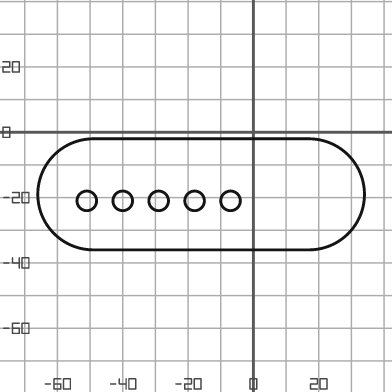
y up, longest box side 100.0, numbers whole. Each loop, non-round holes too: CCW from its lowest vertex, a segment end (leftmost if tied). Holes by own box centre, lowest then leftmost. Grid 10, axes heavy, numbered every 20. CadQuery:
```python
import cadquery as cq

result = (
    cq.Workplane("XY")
    .moveTo(-49.0, -36.0)
    .lineTo(17.0, -36.0)
    .threePointArc((34.0, -19.0), (17.0, -2.0))
    .lineTo(-49.0, -2.0)
    .threePointArc((-66.0, -19.0), (-49.0, -36.0))
    .close()
    .moveTo(-51.0, -21.0)
    .circle(3.0)
    .moveTo(-40.0, -21.0)
    .circle(3.0)
    .moveTo(-29.0, -21.0)
    .circle(3.0)
    .moveTo(-18.0, -21.0)
    .circle(3.0)
    .moveTo(-7.0, -21.0)
    .circle(3.0)
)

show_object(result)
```